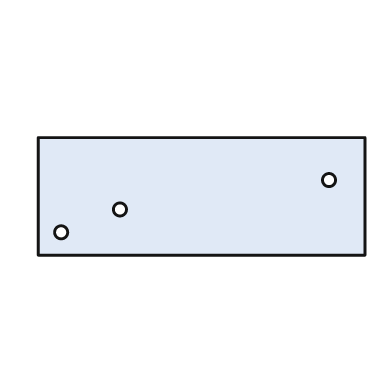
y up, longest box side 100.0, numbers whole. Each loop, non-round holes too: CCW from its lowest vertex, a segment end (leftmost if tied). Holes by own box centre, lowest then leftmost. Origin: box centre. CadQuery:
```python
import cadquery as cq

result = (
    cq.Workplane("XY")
    .moveTo(-50.0, -18.0)
    .lineTo(50.0, -18.0)
    .lineTo(50.0, 18.0)
    .lineTo(-50.0, 18.0)
    .close()
    .moveTo(-43.0, -11.0)
    .circle(2.0)
    .moveTo(-25.0, -4.0)
    .circle(2.0)
    .moveTo(39.0, 5.0)
    .circle(2.0)
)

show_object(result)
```